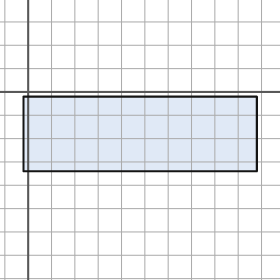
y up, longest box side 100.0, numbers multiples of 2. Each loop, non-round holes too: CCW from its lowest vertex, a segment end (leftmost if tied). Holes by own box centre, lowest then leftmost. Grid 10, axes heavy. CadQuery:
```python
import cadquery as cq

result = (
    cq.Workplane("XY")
    .moveTo(-2.0, -34.0)
    .lineTo(98.0, -34.0)
    .lineTo(98.0, -2.0)
    .lineTo(-2.0, -2.0)
    .close()
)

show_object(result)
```